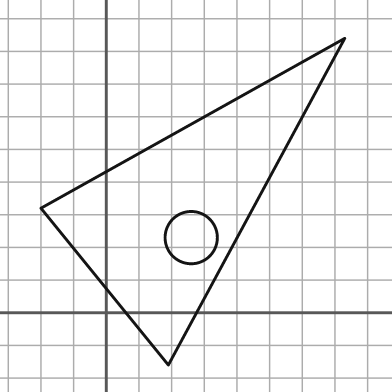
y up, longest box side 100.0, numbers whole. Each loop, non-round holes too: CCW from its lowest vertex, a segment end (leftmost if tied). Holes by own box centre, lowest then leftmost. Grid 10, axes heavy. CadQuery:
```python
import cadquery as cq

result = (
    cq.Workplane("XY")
    .moveTo(19.0, -16.0)
    .lineTo(73.0, 84.0)
    .lineTo(-20.0, 32.0)
    .close()
    .moveTo(26.0, 23.0)
    .circle(8.0)
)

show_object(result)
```